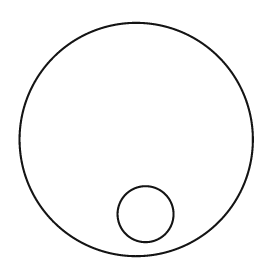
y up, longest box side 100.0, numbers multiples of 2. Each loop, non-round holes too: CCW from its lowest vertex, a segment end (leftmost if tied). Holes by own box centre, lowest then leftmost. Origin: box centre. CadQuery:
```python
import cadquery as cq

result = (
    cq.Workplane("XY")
    .moveTo(0.0, 0.0)
    .circle(50.0)
    .moveTo(4.0, -32.0)
    .circle(12.0)
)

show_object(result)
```